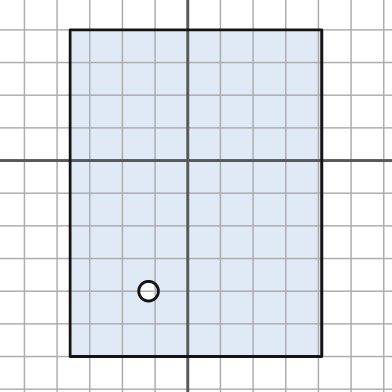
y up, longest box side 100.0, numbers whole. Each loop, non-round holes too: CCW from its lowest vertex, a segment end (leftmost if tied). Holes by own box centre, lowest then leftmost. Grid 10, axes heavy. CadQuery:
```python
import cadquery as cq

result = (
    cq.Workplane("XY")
    .moveTo(-36.0, -60.0)
    .lineTo(41.0, -60.0)
    .lineTo(41.0, 40.0)
    .lineTo(-36.0, 40.0)
    .close()
    .moveTo(-12.0, -40.0)
    .circle(3.0)
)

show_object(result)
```